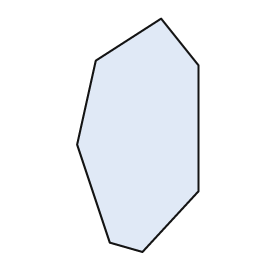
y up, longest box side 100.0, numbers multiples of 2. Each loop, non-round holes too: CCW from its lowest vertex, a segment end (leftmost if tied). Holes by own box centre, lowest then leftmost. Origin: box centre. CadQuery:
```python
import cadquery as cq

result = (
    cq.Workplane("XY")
    .moveTo(2.0, -50.0)
    .lineTo(26.0, -24.0)
    .lineTo(26.0, 30.0)
    .lineTo(10.0, 50.0)
    .lineTo(-18.0, 32.0)
    .lineTo(-26.0, -4.0)
    .lineTo(-12.0, -46.0)
    .close()
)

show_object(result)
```